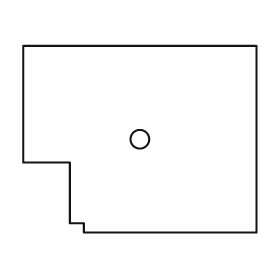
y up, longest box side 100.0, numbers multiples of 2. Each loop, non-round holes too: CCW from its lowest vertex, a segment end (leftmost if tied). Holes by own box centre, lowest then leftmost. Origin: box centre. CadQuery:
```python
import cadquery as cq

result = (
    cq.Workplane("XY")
    .moveTo(-24.0, -40.0)
    .lineTo(50.0, -40.0)
    .lineTo(50.0, 40.0)
    .lineTo(-50.0, 40.0)
    .lineTo(-50.0, -10.0)
    .lineTo(-30.0, -10.0)
    .lineTo(-30.0, -36.0)
    .lineTo(-24.0, -36.0)
    .close()
    .moveTo(0.0, 0.0)
    .circle(4.0)
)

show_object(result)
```